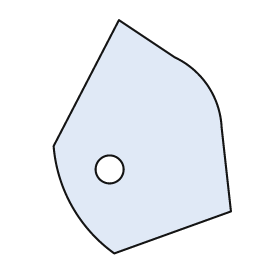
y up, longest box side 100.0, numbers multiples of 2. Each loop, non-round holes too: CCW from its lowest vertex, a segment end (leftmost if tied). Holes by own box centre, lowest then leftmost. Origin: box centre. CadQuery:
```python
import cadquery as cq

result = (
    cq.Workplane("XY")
    .moveTo(-12.0, -50.0)
    .lineTo(38.0, -32.0)
    .lineTo(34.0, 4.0)
    .threePointArc((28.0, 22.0), (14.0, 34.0))
    .lineTo(-10.0, 50.0)
    .lineTo(-38.0, -4.0)
    .threePointArc((-30.0, -30.0), (-12.0, -50.0))
    .close()
    .moveTo(-14.0, -14.0)
    .circle(6.0)
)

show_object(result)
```